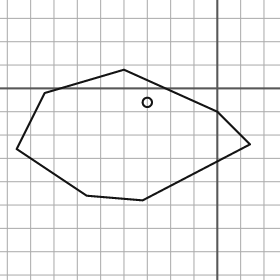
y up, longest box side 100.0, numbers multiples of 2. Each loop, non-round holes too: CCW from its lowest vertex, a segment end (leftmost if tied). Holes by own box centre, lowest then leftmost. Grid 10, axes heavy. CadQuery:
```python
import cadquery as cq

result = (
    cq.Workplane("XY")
    .moveTo(-32.0, -48.0)
    .lineTo(14.0, -24.0)
    .lineTo(0.0, -10.0)
    .lineTo(-40.0, 8.0)
    .lineTo(-74.0, -2.0)
    .lineTo(-86.0, -26.0)
    .lineTo(-56.0, -46.0)
    .close()
    .moveTo(-30.0, -6.0)
    .circle(2.0)
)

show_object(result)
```